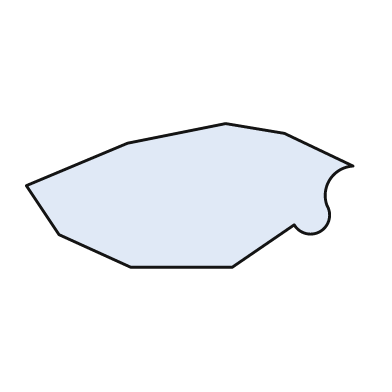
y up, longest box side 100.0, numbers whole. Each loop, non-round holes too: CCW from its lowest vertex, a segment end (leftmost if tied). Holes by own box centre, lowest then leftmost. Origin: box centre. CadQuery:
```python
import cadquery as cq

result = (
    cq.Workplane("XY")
    .moveTo(-18.0, -22.0)
    .lineTo(13.0, -22.0)
    .lineTo(32.0, -9.0)
    .threePointArc((40.0, -11.0), (42.0, -3.0))
    .threePointArc((43.0, 5.0), (50.0, 9.0))
    .lineTo(29.0, 19.0)
    .lineTo(11.0, 22.0)
    .lineTo(-19.0, 16.0)
    .lineTo(-50.0, 3.0)
    .lineTo(-40.0, -12.0)
    .close()
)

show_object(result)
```